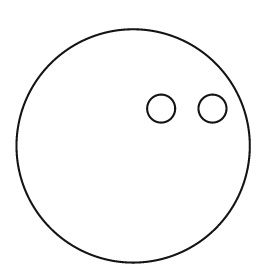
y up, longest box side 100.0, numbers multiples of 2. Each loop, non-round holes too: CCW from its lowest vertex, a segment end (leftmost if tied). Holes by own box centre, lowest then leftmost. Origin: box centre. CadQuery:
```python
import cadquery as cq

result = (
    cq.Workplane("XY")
    .moveTo(0.0, 0.0)
    .circle(50.0)
    .moveTo(12.0, 16.0)
    .circle(6.0)
    .moveTo(34.0, 16.0)
    .circle(6.0)
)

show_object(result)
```